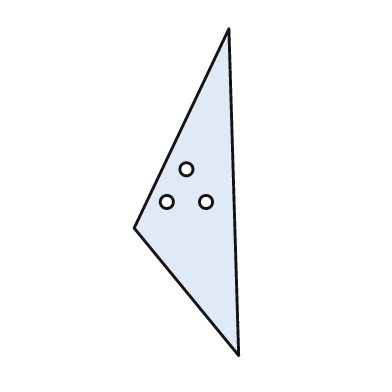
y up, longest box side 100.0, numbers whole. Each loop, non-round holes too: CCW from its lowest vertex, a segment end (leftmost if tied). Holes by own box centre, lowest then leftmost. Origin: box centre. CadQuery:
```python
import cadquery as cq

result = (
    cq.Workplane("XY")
    .moveTo(16.0, -50.0)
    .lineTo(13.0, 50.0)
    .lineTo(-16.0, -11.0)
    .close()
    .moveTo(-6.0, -3.0)
    .circle(2.0)
    .moveTo(6.0, -3.0)
    .circle(2.0)
    .moveTo(0.0, 7.0)
    .circle(2.0)
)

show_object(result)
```